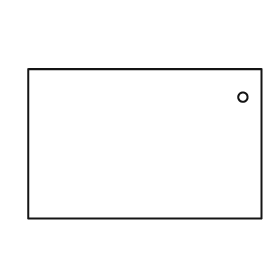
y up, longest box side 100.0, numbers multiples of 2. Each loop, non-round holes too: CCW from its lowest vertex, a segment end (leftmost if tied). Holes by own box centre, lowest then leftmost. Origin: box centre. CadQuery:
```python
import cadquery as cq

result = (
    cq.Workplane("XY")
    .moveTo(-50.0, -32.0)
    .lineTo(50.0, -32.0)
    .lineTo(50.0, 32.0)
    .lineTo(-50.0, 32.0)
    .close()
    .moveTo(42.0, 20.0)
    .circle(2.0)
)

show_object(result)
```